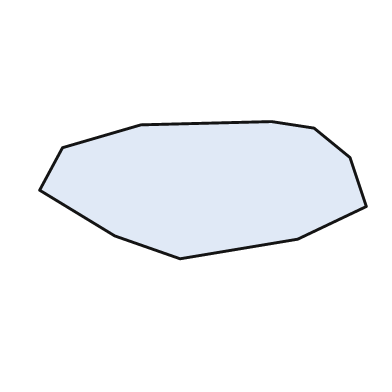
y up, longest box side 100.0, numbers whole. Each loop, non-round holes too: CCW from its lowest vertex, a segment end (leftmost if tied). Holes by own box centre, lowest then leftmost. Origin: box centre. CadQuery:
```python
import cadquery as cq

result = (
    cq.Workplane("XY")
    .moveTo(-7.0, -21.0)
    .lineTo(29.0, -15.0)
    .lineTo(50.0, -5.0)
    .lineTo(45.0, 10.0)
    .lineTo(34.0, 19.0)
    .lineTo(21.0, 21.0)
    .lineTo(-19.0, 20.0)
    .lineTo(-43.0, 13.0)
    .lineTo(-50.0, 0.0)
    .lineTo(-27.0, -14.0)
    .close()
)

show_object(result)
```